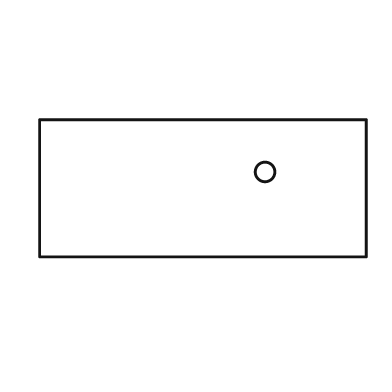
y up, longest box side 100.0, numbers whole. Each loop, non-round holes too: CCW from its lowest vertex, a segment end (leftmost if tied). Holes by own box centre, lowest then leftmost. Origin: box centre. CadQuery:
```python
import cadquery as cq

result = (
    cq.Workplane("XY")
    .moveTo(-50.0, -21.0)
    .lineTo(50.0, -21.0)
    .lineTo(50.0, 21.0)
    .lineTo(-50.0, 21.0)
    .close()
    .moveTo(19.0, 5.0)
    .circle(3.0)
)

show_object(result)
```